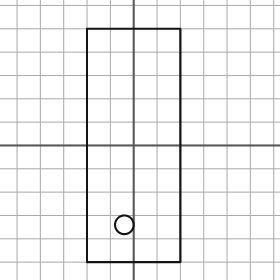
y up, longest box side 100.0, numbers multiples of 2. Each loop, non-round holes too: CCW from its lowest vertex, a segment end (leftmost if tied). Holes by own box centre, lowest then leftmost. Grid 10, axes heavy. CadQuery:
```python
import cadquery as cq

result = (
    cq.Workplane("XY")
    .moveTo(-20.0, -50.0)
    .lineTo(20.0, -50.0)
    .lineTo(20.0, 50.0)
    .lineTo(-20.0, 50.0)
    .close()
    .moveTo(-4.0, -34.0)
    .circle(4.0)
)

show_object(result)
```